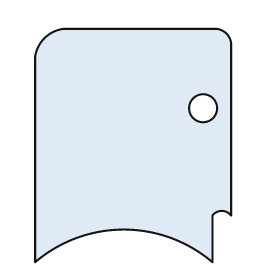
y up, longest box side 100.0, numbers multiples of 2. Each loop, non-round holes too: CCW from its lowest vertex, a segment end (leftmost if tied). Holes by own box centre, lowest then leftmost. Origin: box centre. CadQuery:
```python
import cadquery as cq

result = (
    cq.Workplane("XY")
    .moveTo(-42.0, -50.0)
    .threePointArc((-4.0, -36.0), (34.0, -50.0))
    .lineTo(34.0, -30.0)
    .threePointArc((38.0, -28.0), (42.0, -30.0))
    .lineTo(42.0, 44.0)
    .threePointArc((40.0, 48.0), (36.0, 50.0))
    .lineTo(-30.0, 50.0)
    .threePointArc((-38.0, 46.0), (-42.0, 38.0))
    .close()
    .moveTo(30.0, 16.0)
    .circle(6.0)
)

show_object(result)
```